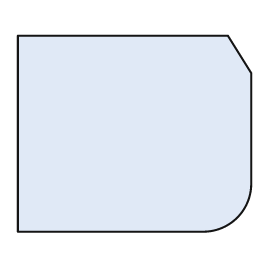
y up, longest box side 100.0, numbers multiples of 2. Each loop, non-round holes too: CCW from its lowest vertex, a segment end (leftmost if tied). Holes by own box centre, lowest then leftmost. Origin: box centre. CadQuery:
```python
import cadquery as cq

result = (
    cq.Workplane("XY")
    .moveTo(-50.0, -42.0)
    .lineTo(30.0, -42.0)
    .threePointArc((44.0, -36.0), (50.0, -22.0))
    .lineTo(50.0, 26.0)
    .lineTo(40.0, 42.0)
    .lineTo(-50.0, 42.0)
    .close()
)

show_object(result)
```